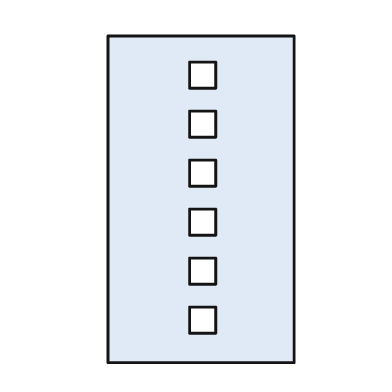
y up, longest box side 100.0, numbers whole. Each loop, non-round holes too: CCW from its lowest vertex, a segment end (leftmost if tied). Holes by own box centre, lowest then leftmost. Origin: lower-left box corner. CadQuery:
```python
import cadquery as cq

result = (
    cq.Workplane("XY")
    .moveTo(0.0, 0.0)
    .lineTo(57.0, 0.0)
    .lineTo(57.0, 100.0)
    .lineTo(0.0, 100.0)
    .close()
    .moveTo(25.0, 9.0)
    .lineTo(33.0, 9.0)
    .lineTo(33.0, 17.0)
    .lineTo(25.0, 17.0)
    .close()
    .moveTo(25.0, 24.0)
    .lineTo(33.0, 24.0)
    .lineTo(33.0, 32.0)
    .lineTo(25.0, 32.0)
    .close()
    .moveTo(25.0, 39.0)
    .lineTo(33.0, 39.0)
    .lineTo(33.0, 47.0)
    .lineTo(25.0, 47.0)
    .close()
    .moveTo(25.0, 54.0)
    .lineTo(33.0, 54.0)
    .lineTo(33.0, 62.0)
    .lineTo(25.0, 62.0)
    .close()
    .moveTo(25.0, 69.0)
    .lineTo(33.0, 69.0)
    .lineTo(33.0, 77.0)
    .lineTo(25.0, 77.0)
    .close()
    .moveTo(25.0, 84.0)
    .lineTo(33.0, 84.0)
    .lineTo(33.0, 92.0)
    .lineTo(25.0, 92.0)
    .close()
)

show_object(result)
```